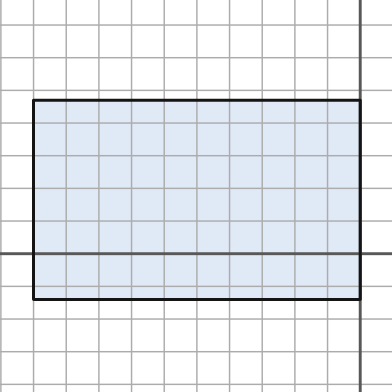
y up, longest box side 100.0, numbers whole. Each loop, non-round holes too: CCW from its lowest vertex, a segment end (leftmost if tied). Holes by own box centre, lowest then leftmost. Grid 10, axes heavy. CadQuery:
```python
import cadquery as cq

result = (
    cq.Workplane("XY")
    .moveTo(-100.0, -14.0)
    .lineTo(0.0, -14.0)
    .lineTo(0.0, 47.0)
    .lineTo(-100.0, 47.0)
    .close()
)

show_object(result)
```